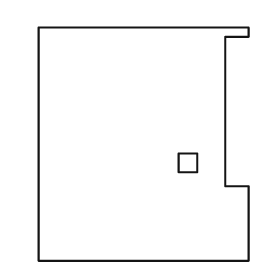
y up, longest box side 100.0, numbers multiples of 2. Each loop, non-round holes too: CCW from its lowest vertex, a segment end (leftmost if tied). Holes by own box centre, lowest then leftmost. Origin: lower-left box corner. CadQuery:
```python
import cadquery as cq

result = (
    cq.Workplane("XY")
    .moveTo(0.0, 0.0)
    .lineTo(90.0, 0.0)
    .lineTo(90.0, 32.0)
    .lineTo(80.0, 32.0)
    .lineTo(80.0, 96.0)
    .lineTo(90.0, 96.0)
    .lineTo(90.0, 100.0)
    .lineTo(0.0, 100.0)
    .close()
    .moveTo(60.0, 38.0)
    .lineTo(68.0, 38.0)
    .lineTo(68.0, 46.0)
    .lineTo(60.0, 46.0)
    .close()
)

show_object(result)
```